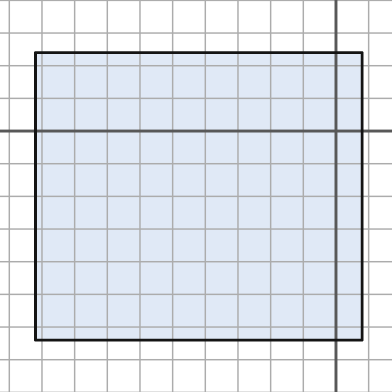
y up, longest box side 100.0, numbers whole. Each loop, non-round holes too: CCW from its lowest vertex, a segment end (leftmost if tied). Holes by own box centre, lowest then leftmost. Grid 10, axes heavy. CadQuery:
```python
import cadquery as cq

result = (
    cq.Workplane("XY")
    .moveTo(-92.0, -64.0)
    .lineTo(8.0, -64.0)
    .lineTo(8.0, 24.0)
    .lineTo(-92.0, 24.0)
    .close()
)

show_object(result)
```